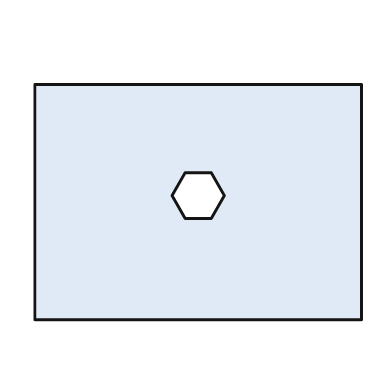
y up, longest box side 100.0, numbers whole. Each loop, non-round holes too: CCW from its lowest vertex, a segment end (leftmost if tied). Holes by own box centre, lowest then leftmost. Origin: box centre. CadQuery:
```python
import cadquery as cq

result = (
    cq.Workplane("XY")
    .moveTo(-50.0, -36.0)
    .lineTo(50.0, -36.0)
    .lineTo(50.0, 36.0)
    .lineTo(-50.0, 36.0)
    .close()
    .moveTo(-4.0, -5.0)
    .lineTo(4.0, -5.0)
    .lineTo(8.0, 2.0)
    .lineTo(4.0, 9.0)
    .lineTo(-4.0, 9.0)
    .lineTo(-8.0, 2.0)
    .close()
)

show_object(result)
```